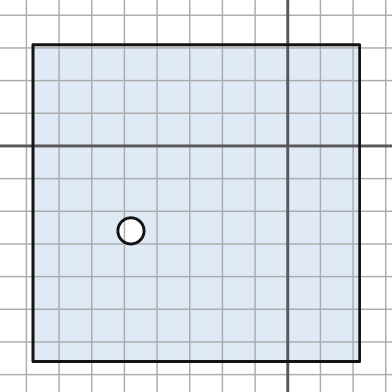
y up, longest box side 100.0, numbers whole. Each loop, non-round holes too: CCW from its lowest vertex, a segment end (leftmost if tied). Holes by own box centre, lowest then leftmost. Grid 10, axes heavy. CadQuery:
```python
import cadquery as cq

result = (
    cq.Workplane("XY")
    .moveTo(-78.0, -66.0)
    .lineTo(22.0, -66.0)
    .lineTo(22.0, 31.0)
    .lineTo(-78.0, 31.0)
    .close()
    .moveTo(-48.0, -26.0)
    .circle(4.0)
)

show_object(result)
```